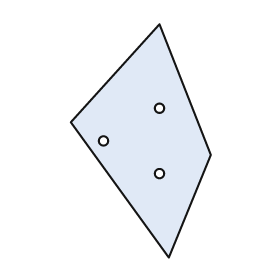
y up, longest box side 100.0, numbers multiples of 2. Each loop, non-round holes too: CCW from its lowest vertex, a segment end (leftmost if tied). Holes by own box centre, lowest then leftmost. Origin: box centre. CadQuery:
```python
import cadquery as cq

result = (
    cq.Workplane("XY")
    .moveTo(12.0, -50.0)
    .lineTo(30.0, -6.0)
    .lineTo(8.0, 50.0)
    .lineTo(-30.0, 8.0)
    .close()
    .moveTo(8.0, -14.0)
    .circle(2.0)
    .moveTo(-16.0, 0.0)
    .circle(2.0)
    .moveTo(8.0, 14.0)
    .circle(2.0)
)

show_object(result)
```